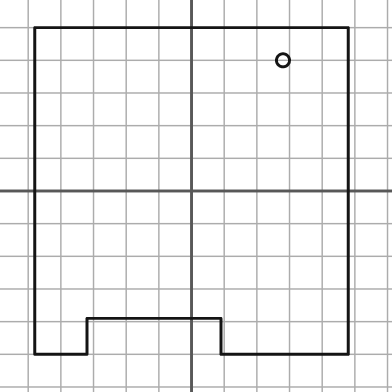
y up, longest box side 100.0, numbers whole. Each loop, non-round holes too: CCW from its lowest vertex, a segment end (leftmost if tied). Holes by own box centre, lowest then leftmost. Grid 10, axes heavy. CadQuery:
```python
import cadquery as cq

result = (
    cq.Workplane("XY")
    .moveTo(-48.0, -50.0)
    .lineTo(-32.0, -50.0)
    .lineTo(-32.0, -39.0)
    .lineTo(9.0, -39.0)
    .lineTo(9.0, -50.0)
    .lineTo(48.0, -50.0)
    .lineTo(48.0, 50.0)
    .lineTo(-48.0, 50.0)
    .close()
    .moveTo(28.0, 40.0)
    .circle(2.0)
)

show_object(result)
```